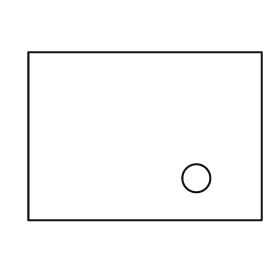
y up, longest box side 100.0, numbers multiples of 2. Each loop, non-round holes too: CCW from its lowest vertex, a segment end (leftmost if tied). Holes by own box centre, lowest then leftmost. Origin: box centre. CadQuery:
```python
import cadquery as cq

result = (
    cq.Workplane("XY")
    .moveTo(-50.0, -36.0)
    .lineTo(50.0, -36.0)
    .lineTo(50.0, 36.0)
    .lineTo(-50.0, 36.0)
    .close()
    .moveTo(22.0, -18.0)
    .circle(6.0)
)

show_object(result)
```